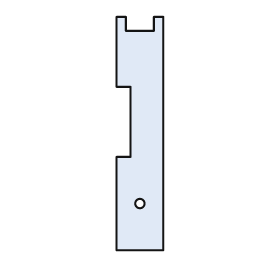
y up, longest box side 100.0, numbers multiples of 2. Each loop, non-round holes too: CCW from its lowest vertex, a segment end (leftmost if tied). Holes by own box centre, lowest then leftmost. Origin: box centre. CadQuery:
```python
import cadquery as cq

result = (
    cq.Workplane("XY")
    .moveTo(-10.0, -50.0)
    .lineTo(10.0, -50.0)
    .lineTo(10.0, 50.0)
    .lineTo(6.0, 50.0)
    .lineTo(6.0, 44.0)
    .lineTo(-6.0, 44.0)
    .lineTo(-6.0, 50.0)
    .lineTo(-10.0, 50.0)
    .lineTo(-10.0, 20.0)
    .lineTo(-4.0, 20.0)
    .lineTo(-4.0, -10.0)
    .lineTo(-10.0, -10.0)
    .close()
    .moveTo(0.0, -30.0)
    .circle(2.0)
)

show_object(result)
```